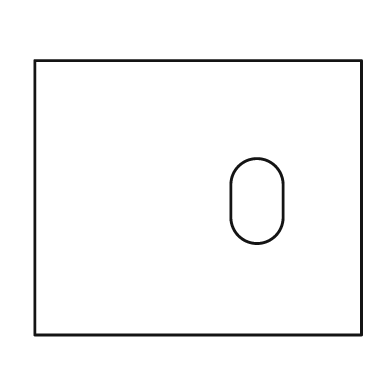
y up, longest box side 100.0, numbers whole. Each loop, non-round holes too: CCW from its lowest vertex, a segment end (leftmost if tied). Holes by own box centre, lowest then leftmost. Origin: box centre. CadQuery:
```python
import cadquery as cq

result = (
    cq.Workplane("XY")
    .moveTo(-50.0, -42.0)
    .lineTo(50.0, -42.0)
    .lineTo(50.0, 42.0)
    .lineTo(-50.0, 42.0)
    .close()
    .moveTo(10.0, -6.0)
    .threePointArc((18.0, -14.0), (26.0, -6.0))
    .lineTo(26.0, 4.0)
    .threePointArc((18.0, 12.0), (10.0, 4.0))
    .close()
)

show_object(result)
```